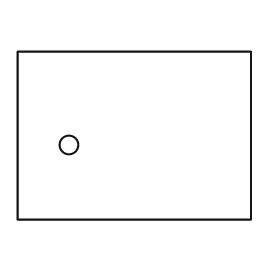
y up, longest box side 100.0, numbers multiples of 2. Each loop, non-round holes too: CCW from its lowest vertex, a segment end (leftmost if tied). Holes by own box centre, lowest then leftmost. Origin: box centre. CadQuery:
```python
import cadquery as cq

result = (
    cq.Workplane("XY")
    .moveTo(-50.0, -36.0)
    .lineTo(50.0, -36.0)
    .lineTo(50.0, 36.0)
    .lineTo(-50.0, 36.0)
    .close()
    .moveTo(-28.0, -4.0)
    .circle(4.0)
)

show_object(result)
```